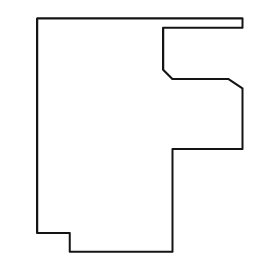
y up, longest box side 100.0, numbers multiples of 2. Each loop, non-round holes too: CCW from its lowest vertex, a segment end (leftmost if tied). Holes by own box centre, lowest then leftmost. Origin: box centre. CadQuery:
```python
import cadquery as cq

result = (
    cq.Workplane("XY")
    .moveTo(-30.0, -50.0)
    .lineTo(14.0, -50.0)
    .lineTo(14.0, -6.0)
    .lineTo(44.0, -6.0)
    .lineTo(44.0, 20.0)
    .lineTo(38.0, 24.0)
    .lineTo(14.0, 24.0)
    .lineTo(10.0, 28.0)
    .lineTo(10.0, 46.0)
    .lineTo(44.0, 46.0)
    .lineTo(44.0, 50.0)
    .lineTo(-44.0, 50.0)
    .lineTo(-44.0, -42.0)
    .lineTo(-30.0, -42.0)
    .close()
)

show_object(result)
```